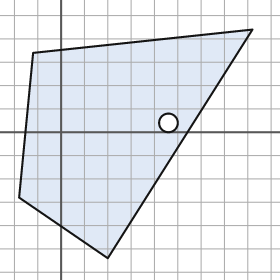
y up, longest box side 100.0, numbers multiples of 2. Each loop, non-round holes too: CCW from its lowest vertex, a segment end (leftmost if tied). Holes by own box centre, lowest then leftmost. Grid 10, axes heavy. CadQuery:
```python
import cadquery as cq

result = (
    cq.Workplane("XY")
    .moveTo(20.0, -54.0)
    .lineTo(82.0, 44.0)
    .lineTo(-12.0, 34.0)
    .lineTo(-18.0, -28.0)
    .close()
    .moveTo(46.0, 4.0)
    .circle(4.0)
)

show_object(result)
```